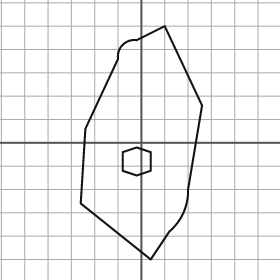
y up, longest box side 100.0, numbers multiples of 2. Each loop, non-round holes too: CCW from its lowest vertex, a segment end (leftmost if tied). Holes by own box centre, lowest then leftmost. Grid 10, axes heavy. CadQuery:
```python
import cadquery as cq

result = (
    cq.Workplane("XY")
    .moveTo(4.0, -50.0)
    .lineTo(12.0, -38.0)
    .threePointArc((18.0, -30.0), (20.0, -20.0))
    .lineTo(26.0, 16.0)
    .lineTo(10.0, 50.0)
    .lineTo(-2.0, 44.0)
    .threePointArc((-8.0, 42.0), (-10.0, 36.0))
    .lineTo(-24.0, 6.0)
    .lineTo(-26.0, -26.0)
    .close()
    .moveTo(-2.0, -14.0)
    .lineTo(4.0, -12.0)
    .lineTo(4.0, -4.0)
    .lineTo(-2.0, -2.0)
    .lineTo(-8.0, -4.0)
    .lineTo(-8.0, -12.0)
    .close()
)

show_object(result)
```